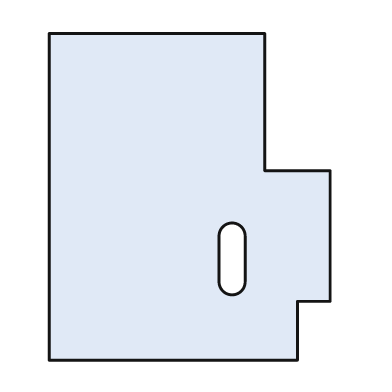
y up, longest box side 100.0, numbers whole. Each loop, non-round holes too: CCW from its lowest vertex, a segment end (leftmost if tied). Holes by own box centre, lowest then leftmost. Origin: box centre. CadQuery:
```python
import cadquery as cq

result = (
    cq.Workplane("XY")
    .moveTo(-43.0, -50.0)
    .lineTo(33.0, -50.0)
    .lineTo(33.0, -32.0)
    .lineTo(43.0, -32.0)
    .lineTo(43.0, 8.0)
    .lineTo(23.0, 8.0)
    .lineTo(23.0, 50.0)
    .lineTo(-43.0, 50.0)
    .close()
    .moveTo(9.0, -26.0)
    .threePointArc((13.0, -30.0), (17.0, -26.0))
    .lineTo(17.0, -12.0)
    .threePointArc((13.0, -8.0), (9.0, -12.0))
    .close()
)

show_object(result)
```